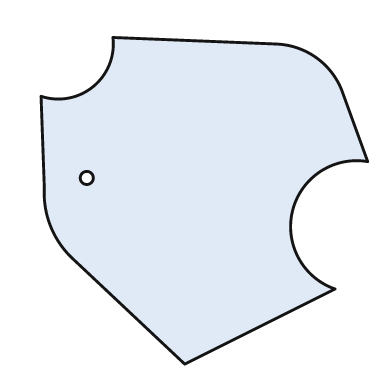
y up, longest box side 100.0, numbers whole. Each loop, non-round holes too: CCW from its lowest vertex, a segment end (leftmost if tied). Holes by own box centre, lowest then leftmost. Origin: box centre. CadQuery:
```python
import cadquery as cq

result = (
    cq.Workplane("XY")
    .moveTo(-6.0, -50.0)
    .lineTo(40.0, -27.0)
    .threePointArc((27.0, -3.0), (50.0, 12.0))
    .lineTo(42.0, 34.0)
    .threePointArc((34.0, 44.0), (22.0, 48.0))
    .lineTo(-28.0, 50.0)
    .threePointArc((-34.0, 35.0), (-50.0, 32.0))
    .lineTo(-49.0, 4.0)
    .threePointArc((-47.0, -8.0), (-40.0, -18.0))
    .close()
    .moveTo(-36.0, 7.0)
    .circle(2.0)
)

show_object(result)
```